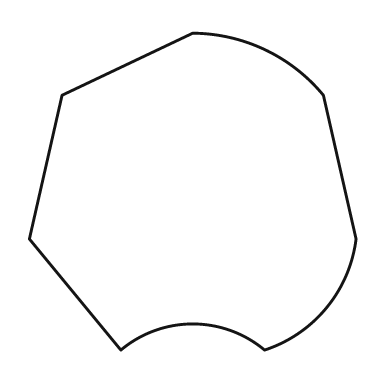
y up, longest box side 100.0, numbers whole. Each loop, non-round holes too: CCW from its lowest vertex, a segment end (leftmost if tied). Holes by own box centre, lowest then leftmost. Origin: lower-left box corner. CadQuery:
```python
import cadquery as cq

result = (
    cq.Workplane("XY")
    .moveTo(28.0, 0.0)
    .threePointArc((50.0, 8.0), (72.0, 0.0))
    .threePointArc((91.0, 13.0), (100.0, 34.0))
    .lineTo(90.0, 78.0)
    .threePointArc((72.0, 92.0), (50.0, 97.0))
    .lineTo(10.0, 78.0)
    .lineTo(0.0, 34.0)
    .close()
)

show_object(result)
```